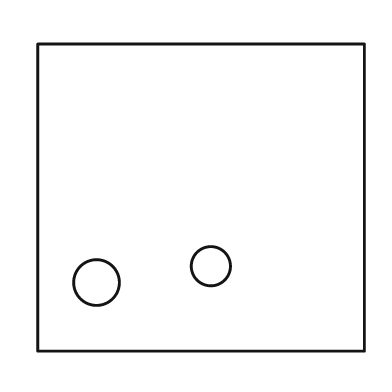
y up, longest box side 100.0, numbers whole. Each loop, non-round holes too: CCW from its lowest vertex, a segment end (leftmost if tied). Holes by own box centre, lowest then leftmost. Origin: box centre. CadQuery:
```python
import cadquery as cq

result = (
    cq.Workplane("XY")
    .moveTo(-50.0, -47.0)
    .lineTo(50.0, -47.0)
    .lineTo(50.0, 47.0)
    .lineTo(-50.0, 47.0)
    .close()
    .moveTo(-32.0, -26.0)
    .circle(7.0)
    .moveTo(3.0, -21.0)
    .circle(6.0)
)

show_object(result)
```